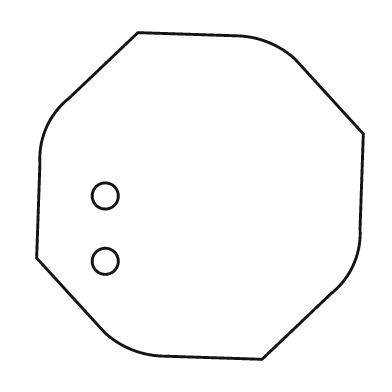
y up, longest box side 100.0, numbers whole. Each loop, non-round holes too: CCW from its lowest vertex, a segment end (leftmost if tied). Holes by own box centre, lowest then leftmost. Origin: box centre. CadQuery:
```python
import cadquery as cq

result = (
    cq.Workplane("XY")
    .moveTo(19.0, -50.0)
    .lineTo(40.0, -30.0)
    .threePointArc((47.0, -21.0), (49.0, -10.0))
    .lineTo(50.0, 19.0)
    .lineTo(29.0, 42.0)
    .threePointArc((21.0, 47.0), (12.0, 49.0))
    .lineTo(-19.0, 50.0)
    .lineTo(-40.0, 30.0)
    .threePointArc((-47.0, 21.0), (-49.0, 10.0))
    .lineTo(-50.0, -19.0)
    .lineTo(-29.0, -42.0)
    .threePointArc((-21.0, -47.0), (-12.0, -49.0))
    .close()
    .moveTo(-29.0, -20.0)
    .circle(4.0)
    .moveTo(-29.0, 0.0)
    .circle(4.0)
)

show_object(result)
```